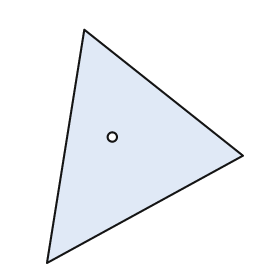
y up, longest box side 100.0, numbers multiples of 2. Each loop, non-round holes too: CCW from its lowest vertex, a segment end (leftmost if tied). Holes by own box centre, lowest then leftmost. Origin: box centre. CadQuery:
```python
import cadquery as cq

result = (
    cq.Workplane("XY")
    .moveTo(-42.0, -50.0)
    .lineTo(42.0, -4.0)
    .lineTo(-26.0, 50.0)
    .close()
    .moveTo(-14.0, 4.0)
    .circle(2.0)
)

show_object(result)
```